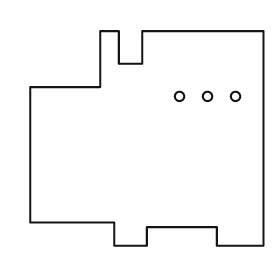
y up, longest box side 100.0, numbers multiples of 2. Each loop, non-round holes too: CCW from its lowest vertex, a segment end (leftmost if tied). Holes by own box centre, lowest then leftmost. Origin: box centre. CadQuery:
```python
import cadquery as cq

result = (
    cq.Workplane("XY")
    .moveTo(-14.0, -46.0)
    .lineTo(0.0, -46.0)
    .lineTo(0.0, -38.0)
    .lineTo(30.0, -38.0)
    .lineTo(30.0, -46.0)
    .lineTo(50.0, -46.0)
    .lineTo(50.0, 46.0)
    .lineTo(-2.0, 46.0)
    .lineTo(-2.0, 32.0)
    .lineTo(-12.0, 32.0)
    .lineTo(-12.0, 46.0)
    .lineTo(-20.0, 46.0)
    .lineTo(-20.0, 22.0)
    .lineTo(-50.0, 22.0)
    .lineTo(-50.0, -36.0)
    .lineTo(-14.0, -36.0)
    .close()
    .moveTo(14.0, 18.0)
    .circle(2.0)
    .moveTo(26.0, 18.0)
    .circle(2.0)
    .moveTo(38.0, 18.0)
    .circle(2.0)
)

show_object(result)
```